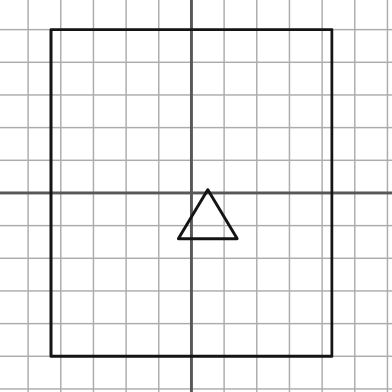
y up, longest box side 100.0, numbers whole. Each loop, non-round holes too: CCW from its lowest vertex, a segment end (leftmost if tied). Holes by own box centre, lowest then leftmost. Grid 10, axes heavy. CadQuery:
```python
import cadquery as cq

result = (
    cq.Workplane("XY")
    .moveTo(-43.0, -50.0)
    .lineTo(43.0, -50.0)
    .lineTo(43.0, 50.0)
    .lineTo(-43.0, 50.0)
    .close()
    .moveTo(-4.0, -14.0)
    .lineTo(14.0, -14.0)
    .lineTo(5.0, 1.0)
    .close()
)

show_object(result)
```